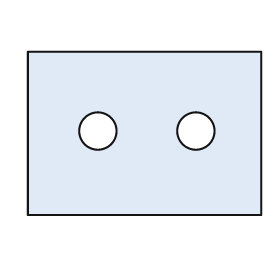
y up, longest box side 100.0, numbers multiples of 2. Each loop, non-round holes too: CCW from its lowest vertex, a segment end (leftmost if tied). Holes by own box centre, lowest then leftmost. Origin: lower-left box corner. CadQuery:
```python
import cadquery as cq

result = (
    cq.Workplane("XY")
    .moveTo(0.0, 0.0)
    .lineTo(100.0, 0.0)
    .lineTo(100.0, 70.0)
    .lineTo(0.0, 70.0)
    .close()
    .moveTo(30.0, 36.0)
    .circle(8.0)
    .moveTo(72.0, 36.0)
    .circle(8.0)
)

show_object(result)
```